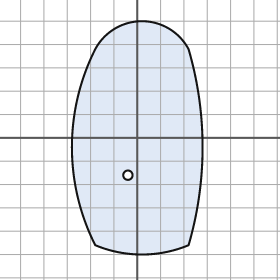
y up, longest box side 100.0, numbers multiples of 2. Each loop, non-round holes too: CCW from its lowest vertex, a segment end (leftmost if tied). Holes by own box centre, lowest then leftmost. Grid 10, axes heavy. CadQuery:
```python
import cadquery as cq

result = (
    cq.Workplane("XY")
    .moveTo(-18.0, -46.0)
    .threePointArc((2.0, -50.0), (22.0, -46.0))
    .threePointArc((28.0, -4.0), (22.0, 38.0))
    .threePointArc((2.0, 50.0), (-18.0, 38.0))
    .threePointArc((-28.0, -4.0), (-18.0, -46.0))
    .close()
    .moveTo(-4.0, -16.0)
    .circle(2.0)
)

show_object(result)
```